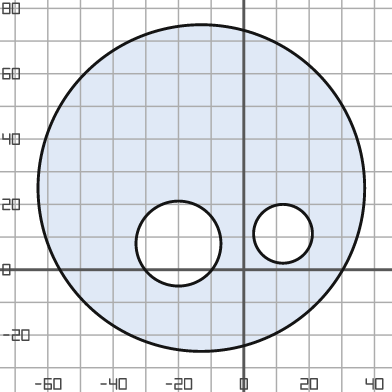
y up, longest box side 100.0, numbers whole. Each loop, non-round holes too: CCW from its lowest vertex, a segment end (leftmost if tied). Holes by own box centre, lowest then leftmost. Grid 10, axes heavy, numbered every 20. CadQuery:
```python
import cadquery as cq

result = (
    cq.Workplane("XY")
    .moveTo(-13.0, 25.0)
    .circle(50.0)
    .moveTo(-20.0, 8.0)
    .circle(13.0)
    .moveTo(12.0, 11.0)
    .circle(9.0)
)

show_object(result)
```